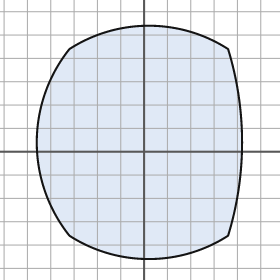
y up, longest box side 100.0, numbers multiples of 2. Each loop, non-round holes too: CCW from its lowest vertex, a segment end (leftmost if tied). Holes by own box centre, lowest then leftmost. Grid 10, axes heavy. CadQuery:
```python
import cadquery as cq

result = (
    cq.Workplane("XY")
    .moveTo(-32.0, -36.0)
    .threePointArc((2.0, -46.0), (36.0, -36.0))
    .threePointArc((42.0, 4.0), (36.0, 44.0))
    .threePointArc((2.0, 54.0), (-32.0, 44.0))
    .threePointArc((-46.0, 4.0), (-32.0, -36.0))
    .close()
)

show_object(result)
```